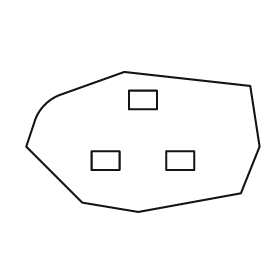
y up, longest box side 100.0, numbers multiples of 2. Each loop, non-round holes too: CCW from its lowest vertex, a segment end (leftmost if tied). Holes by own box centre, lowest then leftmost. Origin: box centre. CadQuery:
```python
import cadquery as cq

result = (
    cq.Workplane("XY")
    .moveTo(-2.0, -30.0)
    .lineTo(42.0, -22.0)
    .lineTo(50.0, -2.0)
    .lineTo(46.0, 24.0)
    .lineTo(-8.0, 30.0)
    .lineTo(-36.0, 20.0)
    .threePointArc((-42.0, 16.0), (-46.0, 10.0))
    .lineTo(-50.0, -2.0)
    .lineTo(-26.0, -26.0)
    .close()
    .moveTo(-22.0, -12.0)
    .lineTo(-10.0, -12.0)
    .lineTo(-10.0, -4.0)
    .lineTo(-22.0, -4.0)
    .close()
    .moveTo(10.0, -12.0)
    .lineTo(22.0, -12.0)
    .lineTo(22.0, -4.0)
    .lineTo(10.0, -4.0)
    .close()
    .moveTo(-6.0, 14.0)
    .lineTo(6.0, 14.0)
    .lineTo(6.0, 22.0)
    .lineTo(-6.0, 22.0)
    .close()
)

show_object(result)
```